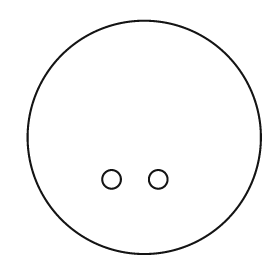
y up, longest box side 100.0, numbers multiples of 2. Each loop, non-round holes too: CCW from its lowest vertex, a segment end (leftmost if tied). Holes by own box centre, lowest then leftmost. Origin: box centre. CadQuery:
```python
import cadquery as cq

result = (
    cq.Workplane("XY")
    .moveTo(0.0, 0.0)
    .circle(50.0)
    .moveTo(-14.0, -18.0)
    .circle(4.0)
    .moveTo(6.0, -18.0)
    .circle(4.0)
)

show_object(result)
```